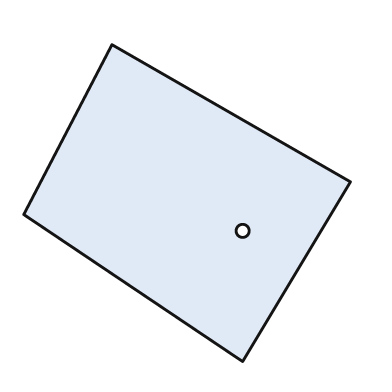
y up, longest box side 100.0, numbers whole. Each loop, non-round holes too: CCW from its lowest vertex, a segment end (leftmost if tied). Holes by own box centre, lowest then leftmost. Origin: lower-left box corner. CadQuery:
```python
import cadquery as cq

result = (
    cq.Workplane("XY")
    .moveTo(67.0, 0.0)
    .lineTo(100.0, 55.0)
    .lineTo(27.0, 97.0)
    .lineTo(0.0, 45.0)
    .close()
    .moveTo(67.0, 40.0)
    .circle(2.0)
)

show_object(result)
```